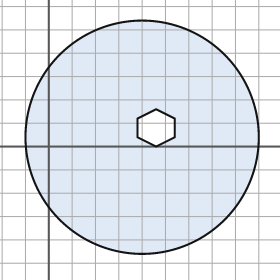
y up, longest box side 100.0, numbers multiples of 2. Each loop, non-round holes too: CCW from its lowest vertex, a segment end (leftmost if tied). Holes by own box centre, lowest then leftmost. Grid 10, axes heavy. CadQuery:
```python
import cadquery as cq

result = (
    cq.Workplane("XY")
    .moveTo(40.0, 4.0)
    .circle(50.0)
    .moveTo(46.0, 0.0)
    .lineTo(54.0, 4.0)
    .lineTo(54.0, 12.0)
    .lineTo(46.0, 16.0)
    .lineTo(38.0, 12.0)
    .lineTo(38.0, 4.0)
    .close()
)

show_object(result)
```